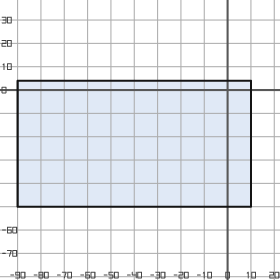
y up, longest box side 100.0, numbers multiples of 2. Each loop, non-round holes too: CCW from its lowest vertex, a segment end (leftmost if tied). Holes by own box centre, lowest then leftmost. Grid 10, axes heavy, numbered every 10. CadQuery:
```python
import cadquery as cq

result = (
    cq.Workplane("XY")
    .moveTo(-90.0, -50.0)
    .lineTo(10.0, -50.0)
    .lineTo(10.0, 4.0)
    .lineTo(-90.0, 4.0)
    .close()
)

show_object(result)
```